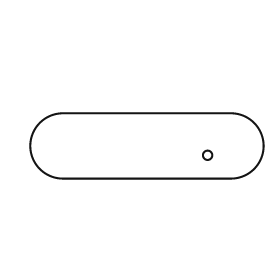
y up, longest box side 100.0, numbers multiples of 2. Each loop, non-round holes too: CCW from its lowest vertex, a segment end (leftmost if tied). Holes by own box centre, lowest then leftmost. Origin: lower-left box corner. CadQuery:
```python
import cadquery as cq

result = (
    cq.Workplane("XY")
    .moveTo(14.0, 0.0)
    .lineTo(86.0, 0.0)
    .threePointArc((100.0, 14.0), (86.0, 28.0))
    .lineTo(14.0, 28.0)
    .threePointArc((0.0, 14.0), (14.0, 0.0))
    .close()
    .moveTo(76.0, 10.0)
    .circle(2.0)
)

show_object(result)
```